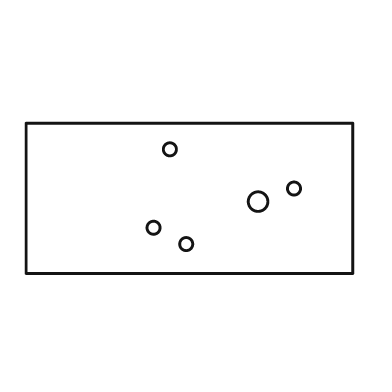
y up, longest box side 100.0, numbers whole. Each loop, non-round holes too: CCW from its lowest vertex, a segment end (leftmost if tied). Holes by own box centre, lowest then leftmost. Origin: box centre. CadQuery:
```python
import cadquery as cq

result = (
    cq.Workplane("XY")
    .moveTo(-50.0, -23.0)
    .lineTo(50.0, -23.0)
    .lineTo(50.0, 23.0)
    .lineTo(-50.0, 23.0)
    .close()
    .moveTo(-1.0, -14.0)
    .circle(2.0)
    .moveTo(-11.0, -9.0)
    .circle(2.0)
    .moveTo(21.0, -1.0)
    .circle(3.0)
    .moveTo(32.0, 3.0)
    .circle(2.0)
    .moveTo(-6.0, 15.0)
    .circle(2.0)
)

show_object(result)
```